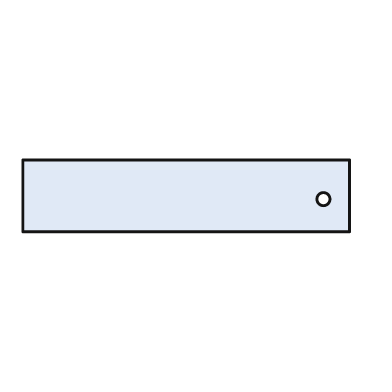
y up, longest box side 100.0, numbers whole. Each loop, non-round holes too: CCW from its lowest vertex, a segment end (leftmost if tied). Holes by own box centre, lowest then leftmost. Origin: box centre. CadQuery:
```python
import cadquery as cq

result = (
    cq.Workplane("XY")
    .moveTo(-50.0, -11.0)
    .lineTo(50.0, -11.0)
    .lineTo(50.0, 11.0)
    .lineTo(-50.0, 11.0)
    .close()
    .moveTo(42.0, -1.0)
    .circle(2.0)
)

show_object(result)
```